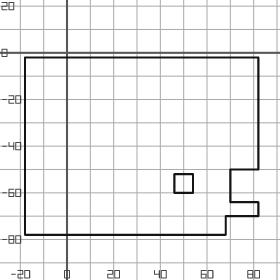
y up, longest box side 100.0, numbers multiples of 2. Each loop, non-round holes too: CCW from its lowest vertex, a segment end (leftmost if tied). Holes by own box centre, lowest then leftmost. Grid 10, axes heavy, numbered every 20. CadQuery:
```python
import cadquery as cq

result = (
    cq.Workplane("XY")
    .moveTo(-18.0, -78.0)
    .lineTo(68.0, -78.0)
    .lineTo(68.0, -70.0)
    .lineTo(82.0, -70.0)
    .lineTo(82.0, -64.0)
    .lineTo(70.0, -64.0)
    .lineTo(70.0, -50.0)
    .lineTo(82.0, -50.0)
    .lineTo(82.0, -2.0)
    .lineTo(-18.0, -2.0)
    .close()
    .moveTo(46.0, -60.0)
    .lineTo(54.0, -60.0)
    .lineTo(54.0, -52.0)
    .lineTo(46.0, -52.0)
    .close()
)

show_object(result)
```